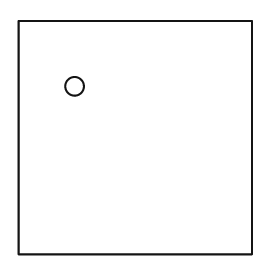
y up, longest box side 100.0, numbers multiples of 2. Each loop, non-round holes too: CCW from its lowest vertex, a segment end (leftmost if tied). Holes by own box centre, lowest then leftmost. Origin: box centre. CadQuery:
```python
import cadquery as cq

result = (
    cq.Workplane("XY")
    .moveTo(-50.0, -50.0)
    .lineTo(50.0, -50.0)
    .lineTo(50.0, 50.0)
    .lineTo(-50.0, 50.0)
    .close()
    .moveTo(-26.0, 22.0)
    .circle(4.0)
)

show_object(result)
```